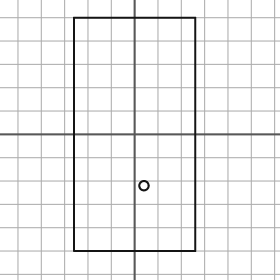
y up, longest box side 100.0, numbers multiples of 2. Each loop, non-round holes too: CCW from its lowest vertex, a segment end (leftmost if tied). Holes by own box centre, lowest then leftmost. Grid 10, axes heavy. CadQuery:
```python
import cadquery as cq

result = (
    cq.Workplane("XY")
    .moveTo(-26.0, -50.0)
    .lineTo(26.0, -50.0)
    .lineTo(26.0, 50.0)
    .lineTo(-26.0, 50.0)
    .close()
    .moveTo(4.0, -22.0)
    .circle(2.0)
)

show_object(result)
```